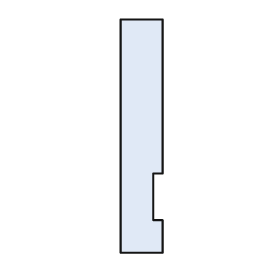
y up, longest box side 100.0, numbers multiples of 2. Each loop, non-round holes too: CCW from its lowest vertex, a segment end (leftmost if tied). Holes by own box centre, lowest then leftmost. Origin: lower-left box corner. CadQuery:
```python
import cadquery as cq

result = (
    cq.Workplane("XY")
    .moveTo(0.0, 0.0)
    .lineTo(18.0, 0.0)
    .lineTo(18.0, 14.0)
    .lineTo(14.0, 14.0)
    .lineTo(14.0, 34.0)
    .lineTo(18.0, 34.0)
    .lineTo(18.0, 100.0)
    .lineTo(0.0, 100.0)
    .close()
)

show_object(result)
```